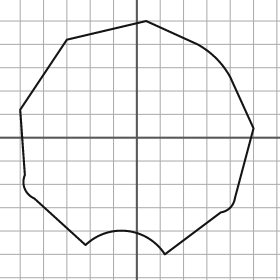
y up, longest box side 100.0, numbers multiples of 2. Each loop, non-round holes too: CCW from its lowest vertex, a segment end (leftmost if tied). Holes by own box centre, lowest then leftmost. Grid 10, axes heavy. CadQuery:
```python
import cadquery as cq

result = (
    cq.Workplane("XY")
    .moveTo(12.0, -50.0)
    .lineTo(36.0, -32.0)
    .threePointArc((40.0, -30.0), (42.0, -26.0))
    .lineTo(50.0, 4.0)
    .lineTo(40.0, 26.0)
    .threePointArc((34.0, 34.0), (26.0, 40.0))
    .lineTo(4.0, 50.0)
    .lineTo(-30.0, 42.0)
    .lineTo(-50.0, 12.0)
    .lineTo(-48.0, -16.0)
    .threePointArc((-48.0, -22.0), (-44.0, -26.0))
    .lineTo(-22.0, -46.0)
    .threePointArc((-4.0, -40.0), (12.0, -50.0))
    .close()
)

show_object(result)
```